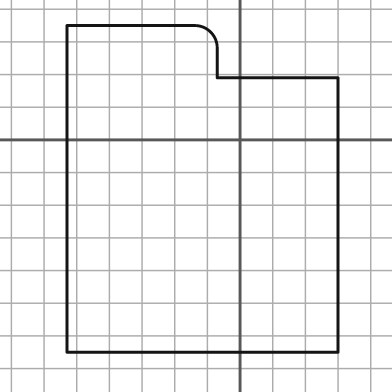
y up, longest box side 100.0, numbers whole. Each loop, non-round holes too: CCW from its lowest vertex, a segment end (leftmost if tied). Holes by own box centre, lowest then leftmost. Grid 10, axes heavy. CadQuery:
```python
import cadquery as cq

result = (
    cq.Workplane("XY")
    .moveTo(-53.0, -65.0)
    .lineTo(30.0, -65.0)
    .lineTo(30.0, 19.0)
    .lineTo(-7.0, 19.0)
    .lineTo(-7.0, 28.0)
    .threePointArc((-9.0, 33.0), (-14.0, 35.0))
    .lineTo(-53.0, 35.0)
    .close()
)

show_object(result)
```